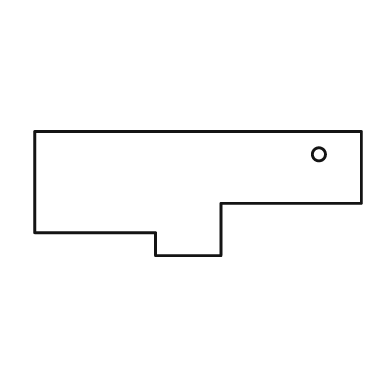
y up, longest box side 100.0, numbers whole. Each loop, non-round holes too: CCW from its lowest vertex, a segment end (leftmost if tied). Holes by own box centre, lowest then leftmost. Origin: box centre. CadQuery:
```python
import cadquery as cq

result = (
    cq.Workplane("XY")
    .moveTo(-13.0, -19.0)
    .lineTo(7.0, -19.0)
    .lineTo(7.0, -3.0)
    .lineTo(50.0, -3.0)
    .lineTo(50.0, 19.0)
    .lineTo(-50.0, 19.0)
    .lineTo(-50.0, -12.0)
    .lineTo(-13.0, -12.0)
    .close()
    .moveTo(37.0, 12.0)
    .circle(2.0)
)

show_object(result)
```